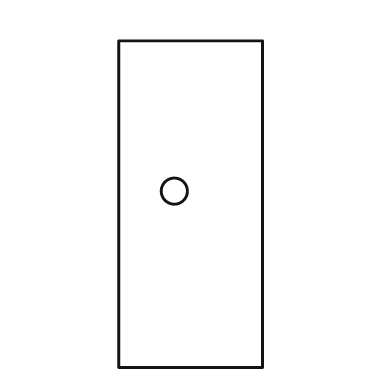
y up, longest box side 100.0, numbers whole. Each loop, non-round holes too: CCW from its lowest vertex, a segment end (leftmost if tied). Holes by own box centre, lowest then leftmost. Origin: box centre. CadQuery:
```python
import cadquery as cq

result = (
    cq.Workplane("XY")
    .moveTo(-22.0, -50.0)
    .lineTo(22.0, -50.0)
    .lineTo(22.0, 50.0)
    .lineTo(-22.0, 50.0)
    .close()
    .moveTo(-5.0, 4.0)
    .circle(4.0)
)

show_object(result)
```